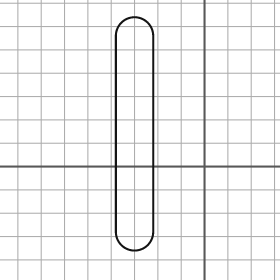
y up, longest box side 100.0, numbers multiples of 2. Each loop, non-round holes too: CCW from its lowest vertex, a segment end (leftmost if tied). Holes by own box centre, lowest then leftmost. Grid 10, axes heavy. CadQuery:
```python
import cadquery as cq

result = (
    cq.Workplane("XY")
    .moveTo(-38.0, -28.0)
    .threePointArc((-30.0, -36.0), (-22.0, -28.0))
    .lineTo(-22.0, 56.0)
    .threePointArc((-30.0, 64.0), (-38.0, 56.0))
    .close()
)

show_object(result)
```